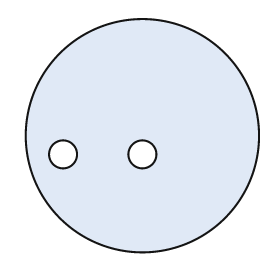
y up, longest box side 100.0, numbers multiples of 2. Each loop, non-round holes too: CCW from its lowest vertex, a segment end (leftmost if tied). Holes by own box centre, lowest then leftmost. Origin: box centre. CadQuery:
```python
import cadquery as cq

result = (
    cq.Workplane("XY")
    .moveTo(0.0, 0.0)
    .circle(50.0)
    .moveTo(-34.0, -8.0)
    .circle(6.0)
    .moveTo(0.0, -8.0)
    .circle(6.0)
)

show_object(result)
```